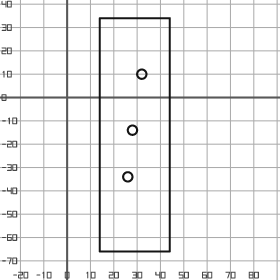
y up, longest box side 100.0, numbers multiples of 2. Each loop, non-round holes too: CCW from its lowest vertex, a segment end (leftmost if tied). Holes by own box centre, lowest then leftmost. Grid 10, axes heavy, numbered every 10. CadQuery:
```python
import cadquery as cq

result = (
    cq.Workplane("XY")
    .moveTo(14.0, -66.0)
    .lineTo(44.0, -66.0)
    .lineTo(44.0, 34.0)
    .lineTo(14.0, 34.0)
    .close()
    .moveTo(26.0, -34.0)
    .circle(2.0)
    .moveTo(28.0, -14.0)
    .circle(2.0)
    .moveTo(32.0, 10.0)
    .circle(2.0)
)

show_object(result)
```